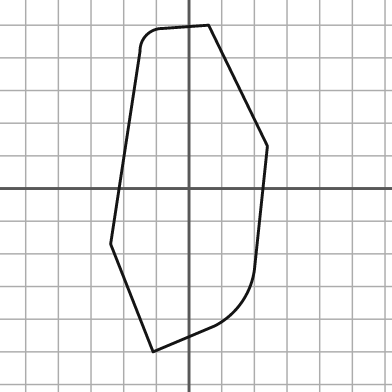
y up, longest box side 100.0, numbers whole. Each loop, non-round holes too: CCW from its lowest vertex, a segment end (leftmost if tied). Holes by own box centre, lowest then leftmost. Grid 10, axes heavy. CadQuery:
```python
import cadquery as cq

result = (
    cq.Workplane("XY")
    .moveTo(-11.0, -50.0)
    .lineTo(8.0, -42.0)
    .threePointArc((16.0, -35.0), (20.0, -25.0))
    .lineTo(24.0, 13.0)
    .lineTo(6.0, 50.0)
    .lineTo(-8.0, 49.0)
    .threePointArc((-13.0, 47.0), (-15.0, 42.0))
    .lineTo(-24.0, -17.0)
    .close()
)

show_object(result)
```